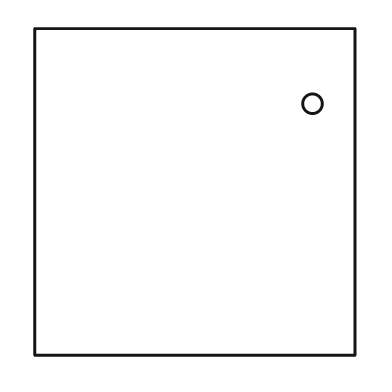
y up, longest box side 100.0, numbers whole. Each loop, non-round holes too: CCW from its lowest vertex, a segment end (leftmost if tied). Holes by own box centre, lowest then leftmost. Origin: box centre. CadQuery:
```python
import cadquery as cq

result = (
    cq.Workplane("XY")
    .moveTo(-49.0, -50.0)
    .lineTo(49.0, -50.0)
    .lineTo(49.0, 50.0)
    .lineTo(-49.0, 50.0)
    .close()
    .moveTo(36.0, 27.0)
    .circle(3.0)
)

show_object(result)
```